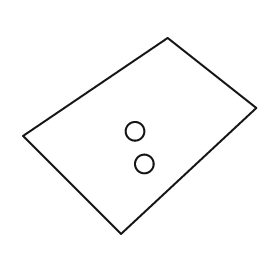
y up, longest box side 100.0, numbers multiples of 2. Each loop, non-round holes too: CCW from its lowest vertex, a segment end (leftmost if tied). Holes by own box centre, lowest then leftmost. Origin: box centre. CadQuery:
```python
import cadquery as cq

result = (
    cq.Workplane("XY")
    .moveTo(-8.0, -42.0)
    .lineTo(50.0, 12.0)
    .lineTo(12.0, 42.0)
    .lineTo(-50.0, 0.0)
    .close()
    .moveTo(2.0, -12.0)
    .circle(4.0)
    .moveTo(-2.0, 2.0)
    .circle(4.0)
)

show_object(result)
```